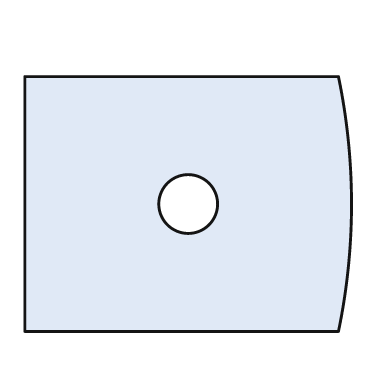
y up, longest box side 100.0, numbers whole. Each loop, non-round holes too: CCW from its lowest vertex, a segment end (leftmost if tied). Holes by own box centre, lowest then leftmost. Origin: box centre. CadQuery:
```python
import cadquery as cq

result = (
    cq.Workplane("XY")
    .moveTo(-50.0, -39.0)
    .lineTo(46.0, -39.0)
    .threePointArc((50.0, 0.0), (46.0, 39.0))
    .lineTo(-50.0, 39.0)
    .close()
    .moveTo(0.0, 0.0)
    .circle(9.0)
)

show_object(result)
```